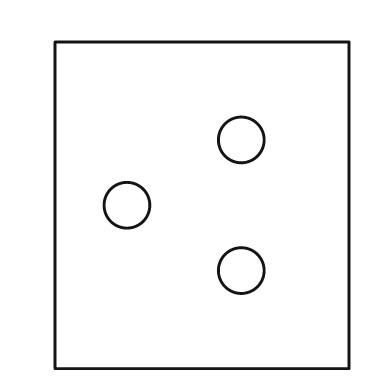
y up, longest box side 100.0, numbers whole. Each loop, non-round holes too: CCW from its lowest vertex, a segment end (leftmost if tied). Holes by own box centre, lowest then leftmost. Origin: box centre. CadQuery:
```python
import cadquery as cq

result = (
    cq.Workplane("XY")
    .moveTo(-45.0, -50.0)
    .lineTo(45.0, -50.0)
    .lineTo(45.0, 50.0)
    .lineTo(-45.0, 50.0)
    .close()
    .moveTo(12.0, -20.0)
    .circle(7.0)
    .moveTo(-23.0, 0.0)
    .circle(7.0)
    .moveTo(12.0, 20.0)
    .circle(7.0)
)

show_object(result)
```